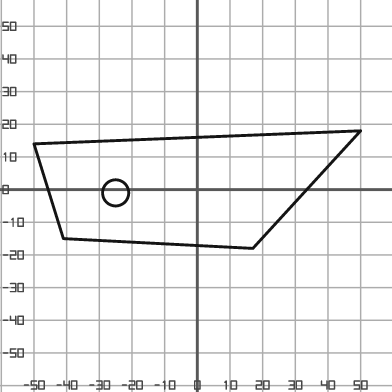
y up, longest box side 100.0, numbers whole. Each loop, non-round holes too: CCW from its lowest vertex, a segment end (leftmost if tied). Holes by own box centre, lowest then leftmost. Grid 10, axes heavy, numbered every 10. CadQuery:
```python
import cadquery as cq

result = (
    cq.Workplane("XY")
    .moveTo(17.0, -18.0)
    .lineTo(50.0, 18.0)
    .lineTo(-50.0, 14.0)
    .lineTo(-41.0, -15.0)
    .close()
    .moveTo(-25.0, -1.0)
    .circle(4.0)
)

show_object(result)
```